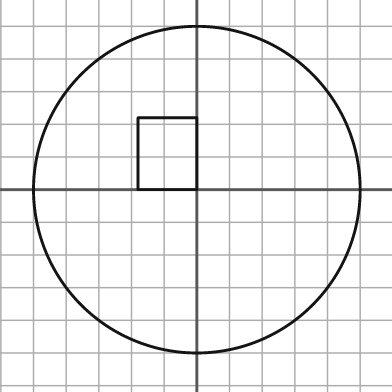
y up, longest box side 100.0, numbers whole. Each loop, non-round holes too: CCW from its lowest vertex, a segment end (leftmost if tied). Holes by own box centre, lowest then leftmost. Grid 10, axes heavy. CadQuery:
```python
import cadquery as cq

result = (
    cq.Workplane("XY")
    .moveTo(0.0, 0.0)
    .circle(50.0)
    .moveTo(-18.0, 0.0)
    .lineTo(0.0, 0.0)
    .lineTo(0.0, 22.0)
    .lineTo(-18.0, 22.0)
    .close()
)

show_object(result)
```